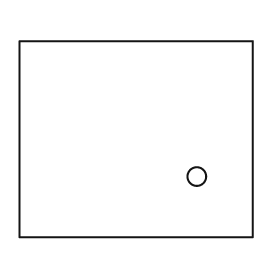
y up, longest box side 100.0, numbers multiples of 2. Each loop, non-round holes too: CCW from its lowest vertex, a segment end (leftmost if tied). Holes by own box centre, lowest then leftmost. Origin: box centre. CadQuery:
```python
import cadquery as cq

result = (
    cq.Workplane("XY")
    .moveTo(-50.0, -42.0)
    .lineTo(50.0, -42.0)
    .lineTo(50.0, 42.0)
    .lineTo(-50.0, 42.0)
    .close()
    .moveTo(26.0, -16.0)
    .circle(4.0)
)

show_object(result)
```